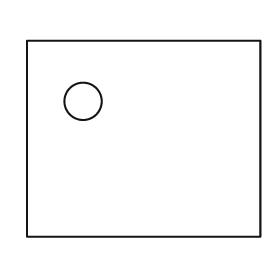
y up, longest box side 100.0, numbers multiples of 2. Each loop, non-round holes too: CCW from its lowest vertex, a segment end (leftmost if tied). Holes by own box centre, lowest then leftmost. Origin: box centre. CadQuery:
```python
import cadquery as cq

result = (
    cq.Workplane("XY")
    .moveTo(-50.0, -42.0)
    .lineTo(50.0, -42.0)
    .lineTo(50.0, 42.0)
    .lineTo(-50.0, 42.0)
    .close()
    .moveTo(-26.0, 16.0)
    .circle(8.0)
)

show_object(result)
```